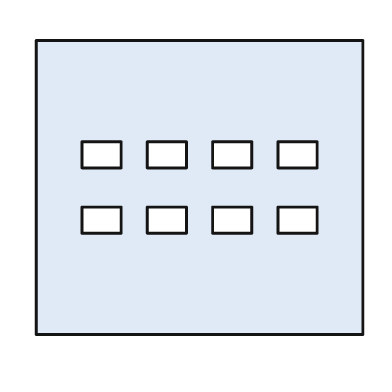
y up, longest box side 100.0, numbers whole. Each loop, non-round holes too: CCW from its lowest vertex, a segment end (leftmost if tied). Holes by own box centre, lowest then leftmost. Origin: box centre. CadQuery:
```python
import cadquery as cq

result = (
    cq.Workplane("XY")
    .moveTo(-50.0, -45.0)
    .lineTo(50.0, -45.0)
    .lineTo(50.0, 45.0)
    .lineTo(-50.0, 45.0)
    .close()
    .moveTo(-36.0, -14.0)
    .lineTo(-24.0, -14.0)
    .lineTo(-24.0, -6.0)
    .lineTo(-36.0, -6.0)
    .close()
    .moveTo(-16.0, -14.0)
    .lineTo(-4.0, -14.0)
    .lineTo(-4.0, -6.0)
    .lineTo(-16.0, -6.0)
    .close()
    .moveTo(4.0, -14.0)
    .lineTo(16.0, -14.0)
    .lineTo(16.0, -6.0)
    .lineTo(4.0, -6.0)
    .close()
    .moveTo(24.0, -14.0)
    .lineTo(36.0, -14.0)
    .lineTo(36.0, -6.0)
    .lineTo(24.0, -6.0)
    .close()
    .moveTo(-36.0, 6.0)
    .lineTo(-24.0, 6.0)
    .lineTo(-24.0, 14.0)
    .lineTo(-36.0, 14.0)
    .close()
    .moveTo(-16.0, 6.0)
    .lineTo(-4.0, 6.0)
    .lineTo(-4.0, 14.0)
    .lineTo(-16.0, 14.0)
    .close()
    .moveTo(4.0, 6.0)
    .lineTo(16.0, 6.0)
    .lineTo(16.0, 14.0)
    .lineTo(4.0, 14.0)
    .close()
    .moveTo(24.0, 6.0)
    .lineTo(36.0, 6.0)
    .lineTo(36.0, 14.0)
    .lineTo(24.0, 14.0)
    .close()
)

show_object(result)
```